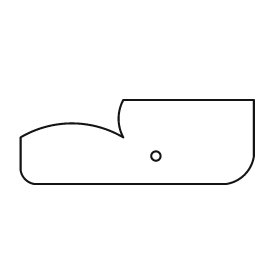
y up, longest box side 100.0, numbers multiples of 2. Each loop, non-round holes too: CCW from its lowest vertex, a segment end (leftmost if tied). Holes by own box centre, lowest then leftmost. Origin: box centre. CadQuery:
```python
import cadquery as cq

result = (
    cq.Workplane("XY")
    .moveTo(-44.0, -18.0)
    .lineTo(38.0, -18.0)
    .threePointArc((46.0, -14.0), (50.0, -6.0))
    .lineTo(50.0, 18.0)
    .lineTo(-6.0, 18.0)
    .threePointArc((-8.0, 10.0), (-6.0, 2.0))
    .threePointArc((-28.0, 8.0), (-50.0, 2.0))
    .lineTo(-50.0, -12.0)
    .threePointArc((-48.0, -16.0), (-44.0, -18.0))
    .close()
    .moveTo(8.0, -6.0)
    .circle(2.0)
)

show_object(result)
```